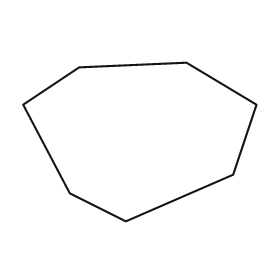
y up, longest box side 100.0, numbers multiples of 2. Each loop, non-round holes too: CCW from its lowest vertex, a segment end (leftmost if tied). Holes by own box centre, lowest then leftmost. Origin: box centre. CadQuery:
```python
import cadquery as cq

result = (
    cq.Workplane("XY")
    .moveTo(-6.0, -34.0)
    .lineTo(40.0, -14.0)
    .lineTo(50.0, 16.0)
    .lineTo(20.0, 34.0)
    .lineTo(-26.0, 32.0)
    .lineTo(-50.0, 16.0)
    .lineTo(-30.0, -22.0)
    .close()
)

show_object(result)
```